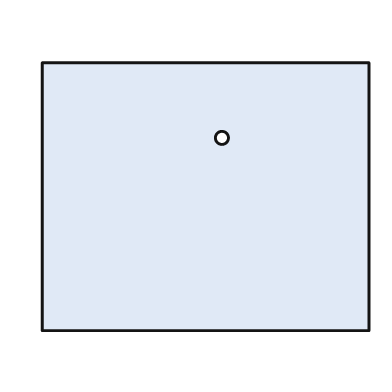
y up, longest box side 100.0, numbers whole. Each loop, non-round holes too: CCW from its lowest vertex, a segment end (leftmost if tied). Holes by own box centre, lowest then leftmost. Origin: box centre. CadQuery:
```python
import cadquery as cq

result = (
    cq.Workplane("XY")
    .moveTo(-50.0, -41.0)
    .lineTo(50.0, -41.0)
    .lineTo(50.0, 41.0)
    .lineTo(-50.0, 41.0)
    .close()
    .moveTo(5.0, 18.0)
    .circle(2.0)
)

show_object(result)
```